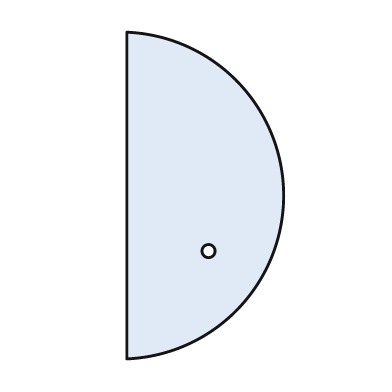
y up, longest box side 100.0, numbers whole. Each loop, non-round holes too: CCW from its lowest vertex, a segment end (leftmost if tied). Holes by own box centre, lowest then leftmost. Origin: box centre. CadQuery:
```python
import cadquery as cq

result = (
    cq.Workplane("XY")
    .moveTo(-24.0, -50.0)
    .threePointArc((24.0, 0.0), (-24.0, 50.0))
    .close()
    .moveTo(1.0, -17.0)
    .circle(2.0)
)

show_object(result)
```